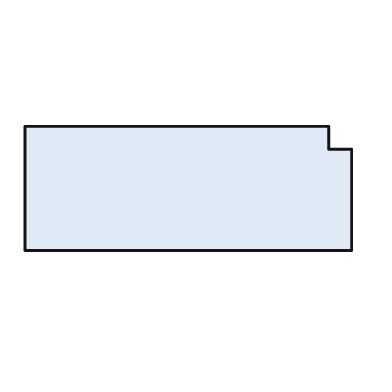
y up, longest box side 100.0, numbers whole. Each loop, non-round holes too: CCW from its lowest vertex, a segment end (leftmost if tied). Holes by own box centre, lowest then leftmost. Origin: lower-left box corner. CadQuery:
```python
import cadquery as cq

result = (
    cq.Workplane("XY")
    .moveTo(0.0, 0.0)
    .lineTo(100.0, 0.0)
    .lineTo(100.0, 31.0)
    .lineTo(93.0, 31.0)
    .lineTo(93.0, 38.0)
    .lineTo(0.0, 38.0)
    .close()
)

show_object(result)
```